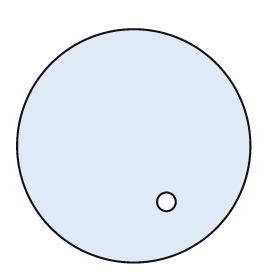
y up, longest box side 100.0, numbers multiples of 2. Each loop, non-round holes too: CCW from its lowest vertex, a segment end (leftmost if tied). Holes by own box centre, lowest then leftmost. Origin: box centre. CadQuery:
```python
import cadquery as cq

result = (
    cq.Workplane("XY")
    .moveTo(0.0, 0.0)
    .circle(50.0)
    .moveTo(14.0, -24.0)
    .circle(4.0)
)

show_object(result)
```